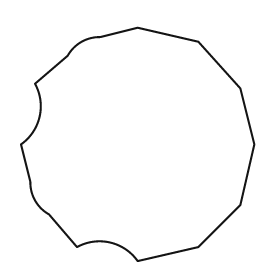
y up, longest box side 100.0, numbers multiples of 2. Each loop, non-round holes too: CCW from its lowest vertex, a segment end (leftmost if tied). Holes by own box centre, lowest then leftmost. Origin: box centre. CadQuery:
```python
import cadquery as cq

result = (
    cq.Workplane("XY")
    .moveTo(0.0, -50.0)
    .lineTo(26.0, -44.0)
    .lineTo(44.0, -26.0)
    .lineTo(50.0, 0.0)
    .lineTo(44.0, 24.0)
    .lineTo(26.0, 44.0)
    .lineTo(0.0, 50.0)
    .lineTo(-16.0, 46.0)
    .threePointArc((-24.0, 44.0), (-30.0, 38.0))
    .lineTo(-44.0, 26.0)
    .threePointArc((-42.0, 12.0), (-50.0, 0.0))
    .lineTo(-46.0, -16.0)
    .threePointArc((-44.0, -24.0), (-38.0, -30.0))
    .lineTo(-26.0, -44.0)
    .threePointArc((-12.0, -42.0), (0.0, -50.0))
    .close()
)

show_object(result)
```